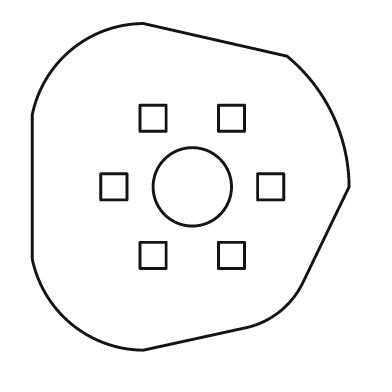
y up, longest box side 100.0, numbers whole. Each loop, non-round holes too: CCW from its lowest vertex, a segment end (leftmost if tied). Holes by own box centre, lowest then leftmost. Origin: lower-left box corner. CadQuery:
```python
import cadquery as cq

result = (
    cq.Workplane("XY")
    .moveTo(34.0, 0.0)
    .lineTo(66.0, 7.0)
    .threePointArc((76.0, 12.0), (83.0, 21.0))
    .lineTo(97.0, 50.0)
    .threePointArc((92.0, 72.0), (78.0, 90.0))
    .lineTo(34.0, 100.0)
    .threePointArc((12.0, 92.0), (0.0, 72.0))
    .lineTo(0.0, 28.0)
    .threePointArc((12.0, 8.0), (34.0, 0.0))
    .close()
    .moveTo(33.0, 25.0)
    .lineTo(41.0, 25.0)
    .lineTo(41.0, 33.0)
    .lineTo(33.0, 33.0)
    .close()
    .moveTo(57.0, 25.0)
    .lineTo(65.0, 25.0)
    .lineTo(65.0, 33.0)
    .lineTo(57.0, 33.0)
    .close()
    .moveTo(21.0, 46.0)
    .lineTo(29.0, 46.0)
    .lineTo(29.0, 54.0)
    .lineTo(21.0, 54.0)
    .close()
    .moveTo(49.0, 50.0)
    .circle(12.0)
    .moveTo(69.0, 46.0)
    .lineTo(77.0, 46.0)
    .lineTo(77.0, 54.0)
    .lineTo(69.0, 54.0)
    .close()
    .moveTo(33.0, 67.0)
    .lineTo(41.0, 67.0)
    .lineTo(41.0, 75.0)
    .lineTo(33.0, 75.0)
    .close()
    .moveTo(57.0, 67.0)
    .lineTo(65.0, 67.0)
    .lineTo(65.0, 75.0)
    .lineTo(57.0, 75.0)
    .close()
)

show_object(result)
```